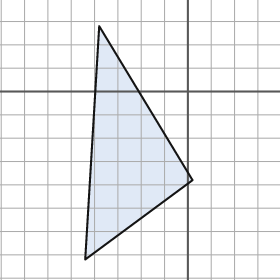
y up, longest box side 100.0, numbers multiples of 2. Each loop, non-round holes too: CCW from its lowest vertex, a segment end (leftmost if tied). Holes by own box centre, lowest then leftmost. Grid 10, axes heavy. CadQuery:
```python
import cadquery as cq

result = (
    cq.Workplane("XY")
    .moveTo(-44.0, -72.0)
    .lineTo(2.0, -38.0)
    .lineTo(-38.0, 28.0)
    .close()
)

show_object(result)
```